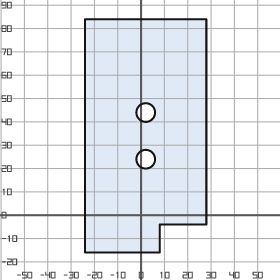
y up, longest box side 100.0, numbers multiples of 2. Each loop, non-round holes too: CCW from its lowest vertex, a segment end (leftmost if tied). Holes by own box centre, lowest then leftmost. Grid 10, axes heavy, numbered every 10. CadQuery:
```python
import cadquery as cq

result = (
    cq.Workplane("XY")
    .moveTo(-24.0, -16.0)
    .lineTo(8.0, -16.0)
    .lineTo(8.0, -4.0)
    .lineTo(28.0, -4.0)
    .lineTo(28.0, 84.0)
    .lineTo(-24.0, 84.0)
    .close()
    .moveTo(2.0, 24.0)
    .circle(4.0)
    .moveTo(2.0, 44.0)
    .circle(4.0)
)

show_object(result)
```